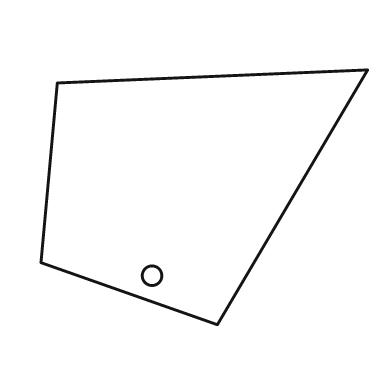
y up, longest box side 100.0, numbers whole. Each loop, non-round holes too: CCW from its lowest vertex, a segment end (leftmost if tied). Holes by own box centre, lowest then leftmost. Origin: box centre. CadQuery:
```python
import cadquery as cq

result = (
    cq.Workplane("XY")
    .moveTo(4.0, -39.0)
    .lineTo(50.0, 39.0)
    .lineTo(-45.0, 35.0)
    .lineTo(-50.0, -20.0)
    .close()
    .moveTo(-16.0, -24.0)
    .circle(3.0)
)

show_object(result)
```